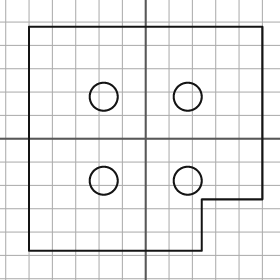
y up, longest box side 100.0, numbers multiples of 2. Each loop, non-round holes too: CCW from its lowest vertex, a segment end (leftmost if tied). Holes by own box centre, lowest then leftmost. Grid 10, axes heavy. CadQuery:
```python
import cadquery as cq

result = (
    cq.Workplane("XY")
    .moveTo(-50.0, -48.0)
    .lineTo(24.0, -48.0)
    .lineTo(24.0, -26.0)
    .lineTo(50.0, -26.0)
    .lineTo(50.0, 48.0)
    .lineTo(-50.0, 48.0)
    .close()
    .moveTo(-18.0, -18.0)
    .circle(6.0)
    .moveTo(18.0, -18.0)
    .circle(6.0)
    .moveTo(-18.0, 18.0)
    .circle(6.0)
    .moveTo(18.0, 18.0)
    .circle(6.0)
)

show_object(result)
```